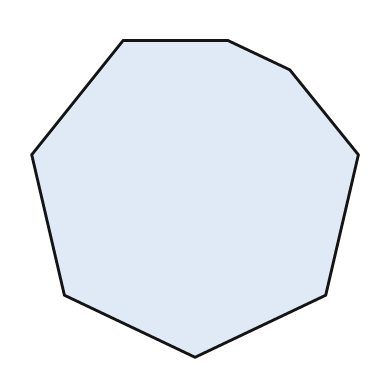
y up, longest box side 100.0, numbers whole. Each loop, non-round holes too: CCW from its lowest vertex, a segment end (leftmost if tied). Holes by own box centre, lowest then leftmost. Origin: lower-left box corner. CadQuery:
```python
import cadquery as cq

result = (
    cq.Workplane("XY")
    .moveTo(50.0, 0.0)
    .lineTo(90.0, 19.0)
    .lineTo(100.0, 62.0)
    .lineTo(79.0, 88.0)
    .lineTo(60.0, 97.0)
    .lineTo(28.0, 97.0)
    .lineTo(0.0, 62.0)
    .lineTo(10.0, 19.0)
    .close()
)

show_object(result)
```